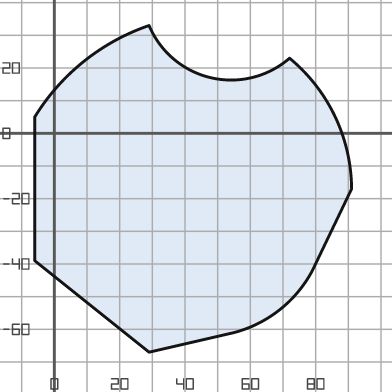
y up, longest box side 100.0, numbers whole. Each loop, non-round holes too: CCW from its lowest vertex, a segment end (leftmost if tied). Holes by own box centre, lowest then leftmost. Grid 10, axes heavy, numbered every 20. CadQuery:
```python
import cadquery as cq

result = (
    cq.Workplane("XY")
    .moveTo(29.0, -67.0)
    .lineTo(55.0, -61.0)
    .threePointArc((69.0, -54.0), (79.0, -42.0))
    .lineTo(91.0, -17.0)
    .threePointArc((86.0, 5.0), (72.0, 23.0))
    .threePointArc((48.0, 17.0), (29.0, 33.0))
    .threePointArc((9.0, 22.0), (-6.0, 5.0))
    .lineTo(-6.0, -39.0)
    .close()
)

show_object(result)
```